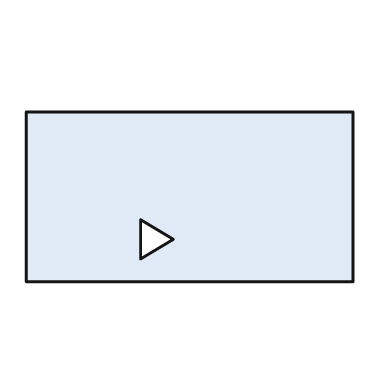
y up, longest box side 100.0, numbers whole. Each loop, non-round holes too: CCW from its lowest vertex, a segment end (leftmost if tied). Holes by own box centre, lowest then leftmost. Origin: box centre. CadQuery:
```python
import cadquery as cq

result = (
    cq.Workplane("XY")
    .moveTo(-50.0, -26.0)
    .lineTo(50.0, -26.0)
    .lineTo(50.0, 26.0)
    .lineTo(-50.0, 26.0)
    .close()
    .moveTo(-15.0, -19.0)
    .lineTo(-5.0, -13.0)
    .lineTo(-15.0, -7.0)
    .close()
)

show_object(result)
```